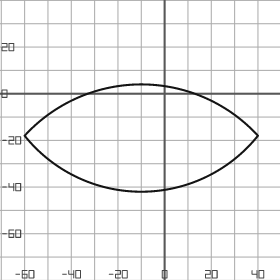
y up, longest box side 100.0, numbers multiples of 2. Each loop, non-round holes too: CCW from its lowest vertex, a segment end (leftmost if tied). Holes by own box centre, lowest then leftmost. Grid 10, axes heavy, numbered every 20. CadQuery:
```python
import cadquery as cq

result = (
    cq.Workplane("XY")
    .moveTo(-60.0, -18.0)
    .threePointArc((-10.0, -42.0), (40.0, -18.0))
    .threePointArc((-10.0, 4.0), (-60.0, -18.0))
    .close()
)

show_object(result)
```